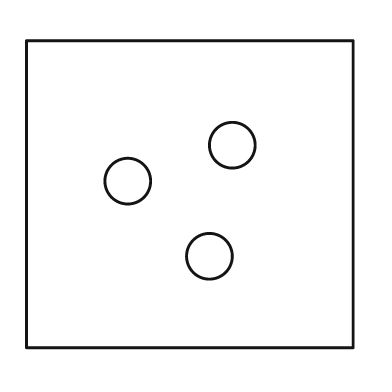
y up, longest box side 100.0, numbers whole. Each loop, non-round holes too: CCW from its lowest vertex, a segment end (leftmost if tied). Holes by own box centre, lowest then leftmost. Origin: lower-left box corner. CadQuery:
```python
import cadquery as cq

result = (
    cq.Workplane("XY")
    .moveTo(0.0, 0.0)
    .lineTo(100.0, 0.0)
    .lineTo(100.0, 94.0)
    .lineTo(0.0, 94.0)
    .close()
    .moveTo(56.0, 28.0)
    .circle(7.0)
    .moveTo(31.0, 51.0)
    .circle(7.0)
    .moveTo(63.0, 62.0)
    .circle(7.0)
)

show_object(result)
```